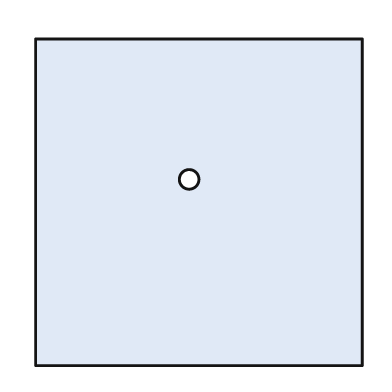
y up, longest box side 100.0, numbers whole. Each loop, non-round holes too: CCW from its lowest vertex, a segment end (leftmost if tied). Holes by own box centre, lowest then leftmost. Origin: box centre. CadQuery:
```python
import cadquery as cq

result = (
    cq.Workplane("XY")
    .moveTo(-50.0, -50.0)
    .lineTo(50.0, -50.0)
    .lineTo(50.0, 50.0)
    .lineTo(-50.0, 50.0)
    .close()
    .moveTo(-3.0, 7.0)
    .circle(3.0)
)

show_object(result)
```